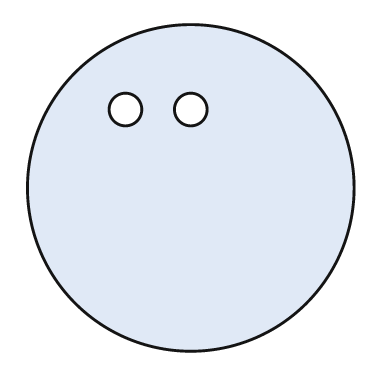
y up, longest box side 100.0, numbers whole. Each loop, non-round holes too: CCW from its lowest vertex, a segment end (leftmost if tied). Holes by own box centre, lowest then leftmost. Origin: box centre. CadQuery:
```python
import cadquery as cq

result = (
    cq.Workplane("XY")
    .moveTo(0.0, 0.0)
    .circle(50.0)
    .moveTo(-20.0, 24.0)
    .circle(5.0)
    .moveTo(0.0, 24.0)
    .circle(5.0)
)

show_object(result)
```